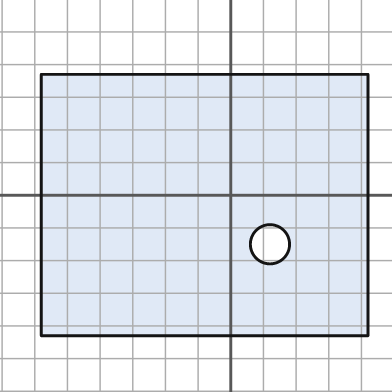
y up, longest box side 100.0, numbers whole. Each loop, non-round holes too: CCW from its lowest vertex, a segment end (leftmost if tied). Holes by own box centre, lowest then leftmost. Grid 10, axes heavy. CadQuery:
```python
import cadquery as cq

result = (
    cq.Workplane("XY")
    .moveTo(-58.0, -43.0)
    .lineTo(42.0, -43.0)
    .lineTo(42.0, 37.0)
    .lineTo(-58.0, 37.0)
    .close()
    .moveTo(12.0, -15.0)
    .circle(6.0)
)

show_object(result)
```